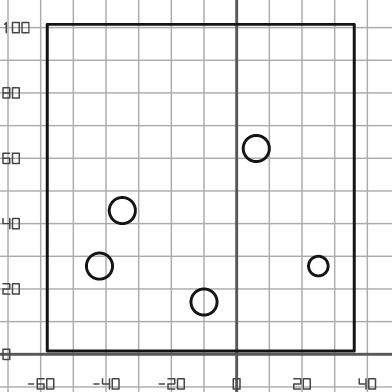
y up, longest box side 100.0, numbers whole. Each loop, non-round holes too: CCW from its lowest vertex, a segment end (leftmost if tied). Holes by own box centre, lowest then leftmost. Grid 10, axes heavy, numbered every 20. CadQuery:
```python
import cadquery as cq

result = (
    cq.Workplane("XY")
    .moveTo(-58.0, 1.0)
    .lineTo(36.0, 1.0)
    .lineTo(36.0, 101.0)
    .lineTo(-58.0, 101.0)
    .close()
    .moveTo(-10.0, 16.0)
    .circle(4.0)
    .moveTo(-42.0, 27.0)
    .circle(4.0)
    .moveTo(25.0, 27.0)
    .circle(3.0)
    .moveTo(-35.0, 44.0)
    .circle(4.0)
    .moveTo(6.0, 63.0)
    .circle(4.0)
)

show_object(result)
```